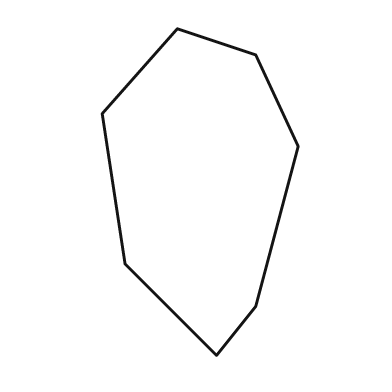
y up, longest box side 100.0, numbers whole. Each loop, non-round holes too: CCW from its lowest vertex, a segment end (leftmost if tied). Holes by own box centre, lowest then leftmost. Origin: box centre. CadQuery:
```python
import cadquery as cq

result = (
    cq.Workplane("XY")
    .moveTo(5.0, -50.0)
    .lineTo(17.0, -35.0)
    .lineTo(30.0, 14.0)
    .lineTo(17.0, 42.0)
    .lineTo(-7.0, 50.0)
    .lineTo(-30.0, 24.0)
    .lineTo(-23.0, -22.0)
    .close()
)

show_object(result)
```